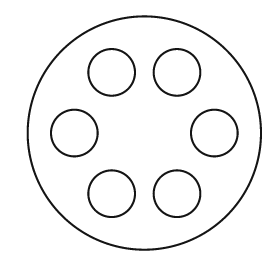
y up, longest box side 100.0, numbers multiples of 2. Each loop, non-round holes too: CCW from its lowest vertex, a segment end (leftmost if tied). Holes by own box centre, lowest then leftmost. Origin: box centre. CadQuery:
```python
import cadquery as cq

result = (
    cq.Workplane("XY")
    .moveTo(0.0, 0.0)
    .circle(50.0)
    .moveTo(-14.0, -26.0)
    .circle(10.0)
    .moveTo(14.0, -26.0)
    .circle(10.0)
    .moveTo(-30.0, 0.0)
    .circle(10.0)
    .moveTo(30.0, 0.0)
    .circle(10.0)
    .moveTo(-14.0, 26.0)
    .circle(10.0)
    .moveTo(14.0, 26.0)
    .circle(10.0)
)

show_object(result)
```